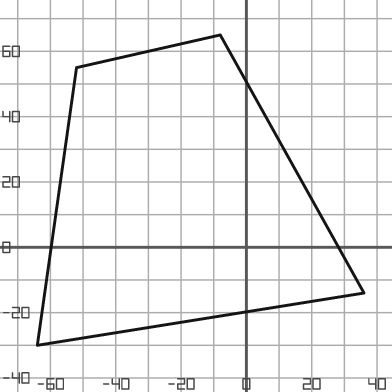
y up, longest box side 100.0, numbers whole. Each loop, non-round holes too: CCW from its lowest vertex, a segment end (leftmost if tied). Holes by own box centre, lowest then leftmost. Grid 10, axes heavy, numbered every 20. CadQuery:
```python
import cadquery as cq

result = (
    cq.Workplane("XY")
    .moveTo(-64.0, -30.0)
    .lineTo(36.0, -14.0)
    .lineTo(-8.0, 65.0)
    .lineTo(-52.0, 55.0)
    .close()
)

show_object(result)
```